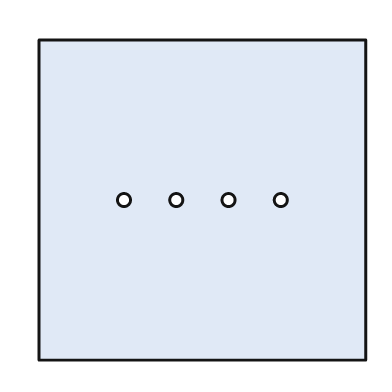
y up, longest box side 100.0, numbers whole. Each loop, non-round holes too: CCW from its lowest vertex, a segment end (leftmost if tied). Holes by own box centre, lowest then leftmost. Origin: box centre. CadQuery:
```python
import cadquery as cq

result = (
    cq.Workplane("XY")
    .moveTo(-50.0, -49.0)
    .lineTo(50.0, -49.0)
    .lineTo(50.0, 49.0)
    .lineTo(-50.0, 49.0)
    .close()
    .moveTo(-24.0, 0.0)
    .circle(2.0)
    .moveTo(-8.0, 0.0)
    .circle(2.0)
    .moveTo(8.0, 0.0)
    .circle(2.0)
    .moveTo(24.0, 0.0)
    .circle(2.0)
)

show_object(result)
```